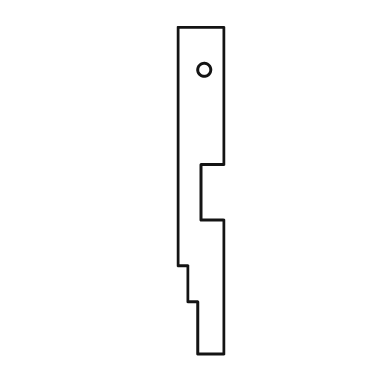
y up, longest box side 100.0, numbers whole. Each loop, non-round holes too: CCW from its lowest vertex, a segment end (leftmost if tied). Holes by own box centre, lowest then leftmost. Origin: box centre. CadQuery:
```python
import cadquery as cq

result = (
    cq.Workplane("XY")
    .moveTo(-1.0, -50.0)
    .lineTo(7.0, -50.0)
    .lineTo(7.0, -9.0)
    .lineTo(0.0, -9.0)
    .lineTo(0.0, 8.0)
    .lineTo(7.0, 8.0)
    .lineTo(7.0, 50.0)
    .lineTo(-7.0, 50.0)
    .lineTo(-7.0, -23.0)
    .lineTo(-4.0, -23.0)
    .lineTo(-4.0, -34.0)
    .lineTo(-1.0, -34.0)
    .close()
    .moveTo(1.0, 37.0)
    .circle(2.0)
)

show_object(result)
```